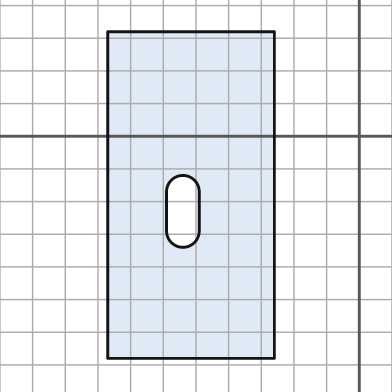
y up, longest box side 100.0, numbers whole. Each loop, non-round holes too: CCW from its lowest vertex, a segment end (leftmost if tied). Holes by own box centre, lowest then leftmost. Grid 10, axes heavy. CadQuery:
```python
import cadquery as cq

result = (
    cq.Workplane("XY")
    .moveTo(-77.0, -68.0)
    .lineTo(-26.0, -68.0)
    .lineTo(-26.0, 32.0)
    .lineTo(-77.0, 32.0)
    .close()
    .moveTo(-59.0, -29.0)
    .threePointArc((-54.0, -34.0), (-49.0, -29.0))
    .lineTo(-49.0, -17.0)
    .threePointArc((-54.0, -12.0), (-59.0, -17.0))
    .close()
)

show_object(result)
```